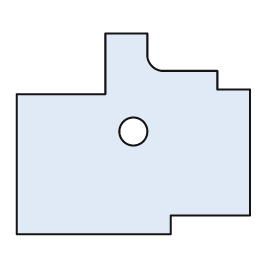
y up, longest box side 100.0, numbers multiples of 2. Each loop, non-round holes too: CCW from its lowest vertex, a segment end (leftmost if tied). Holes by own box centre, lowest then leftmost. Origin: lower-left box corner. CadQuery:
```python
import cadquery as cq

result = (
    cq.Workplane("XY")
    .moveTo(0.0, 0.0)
    .lineTo(66.0, 0.0)
    .lineTo(66.0, 8.0)
    .lineTo(100.0, 8.0)
    .lineTo(100.0, 62.0)
    .lineTo(86.0, 62.0)
    .lineTo(86.0, 70.0)
    .lineTo(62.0, 70.0)
    .threePointArc((58.0, 72.0), (56.0, 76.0))
    .lineTo(56.0, 86.0)
    .lineTo(38.0, 86.0)
    .lineTo(38.0, 60.0)
    .lineTo(0.0, 60.0)
    .close()
    .moveTo(50.0, 44.0)
    .circle(6.0)
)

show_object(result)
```